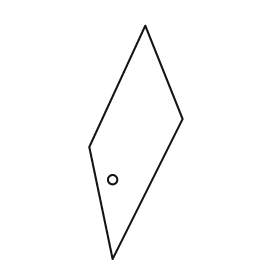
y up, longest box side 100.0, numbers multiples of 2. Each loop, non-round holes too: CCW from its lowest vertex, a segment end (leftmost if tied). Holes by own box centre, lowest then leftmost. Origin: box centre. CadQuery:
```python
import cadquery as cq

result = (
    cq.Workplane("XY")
    .moveTo(-10.0, -50.0)
    .lineTo(20.0, 10.0)
    .lineTo(4.0, 50.0)
    .lineTo(-20.0, -2.0)
    .close()
    .moveTo(-10.0, -16.0)
    .circle(2.0)
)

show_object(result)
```